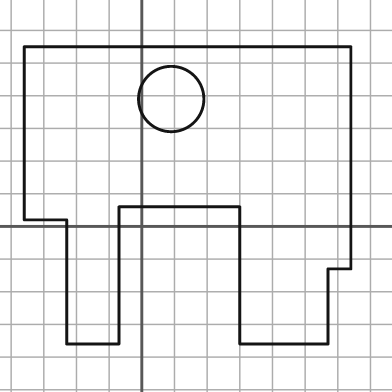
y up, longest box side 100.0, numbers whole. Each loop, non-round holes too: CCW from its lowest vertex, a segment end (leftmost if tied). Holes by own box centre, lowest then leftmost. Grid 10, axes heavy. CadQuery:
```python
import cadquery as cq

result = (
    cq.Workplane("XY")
    .moveTo(-23.0, -36.0)
    .lineTo(-7.0, -36.0)
    .lineTo(-7.0, 6.0)
    .lineTo(30.0, 6.0)
    .lineTo(30.0, -36.0)
    .lineTo(57.0, -36.0)
    .lineTo(57.0, -13.0)
    .lineTo(64.0, -13.0)
    .lineTo(64.0, 55.0)
    .lineTo(-36.0, 55.0)
    .lineTo(-36.0, 2.0)
    .lineTo(-23.0, 2.0)
    .close()
    .moveTo(9.0, 39.0)
    .circle(10.0)
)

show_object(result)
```